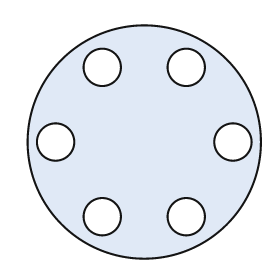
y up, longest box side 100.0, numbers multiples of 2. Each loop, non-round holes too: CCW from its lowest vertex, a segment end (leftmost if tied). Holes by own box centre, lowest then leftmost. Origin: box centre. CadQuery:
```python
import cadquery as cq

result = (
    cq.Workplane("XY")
    .moveTo(0.0, 0.0)
    .circle(50.0)
    .moveTo(-18.0, -32.0)
    .circle(8.0)
    .moveTo(18.0, -32.0)
    .circle(8.0)
    .moveTo(-38.0, 0.0)
    .circle(8.0)
    .moveTo(38.0, 0.0)
    .circle(8.0)
    .moveTo(-18.0, 32.0)
    .circle(8.0)
    .moveTo(18.0, 32.0)
    .circle(8.0)
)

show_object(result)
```